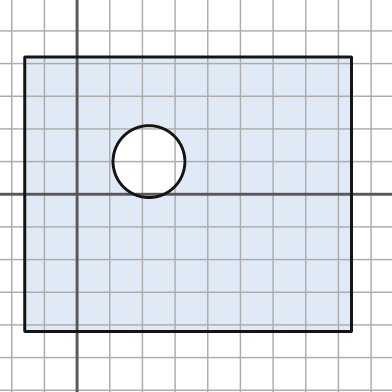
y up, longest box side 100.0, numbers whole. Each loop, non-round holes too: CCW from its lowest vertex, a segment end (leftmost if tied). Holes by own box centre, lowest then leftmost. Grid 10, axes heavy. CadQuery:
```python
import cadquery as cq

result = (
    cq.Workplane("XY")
    .moveTo(-16.0, -42.0)
    .lineTo(84.0, -42.0)
    .lineTo(84.0, 42.0)
    .lineTo(-16.0, 42.0)
    .close()
    .moveTo(22.0, 10.0)
    .circle(11.0)
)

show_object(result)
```